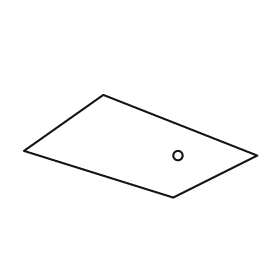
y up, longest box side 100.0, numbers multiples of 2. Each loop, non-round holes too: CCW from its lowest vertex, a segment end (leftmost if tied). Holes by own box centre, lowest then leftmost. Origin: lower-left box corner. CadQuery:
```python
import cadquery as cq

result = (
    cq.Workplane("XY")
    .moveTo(64.0, 0.0)
    .lineTo(100.0, 18.0)
    .lineTo(34.0, 44.0)
    .lineTo(0.0, 20.0)
    .close()
    .moveTo(66.0, 18.0)
    .circle(2.0)
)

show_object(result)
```